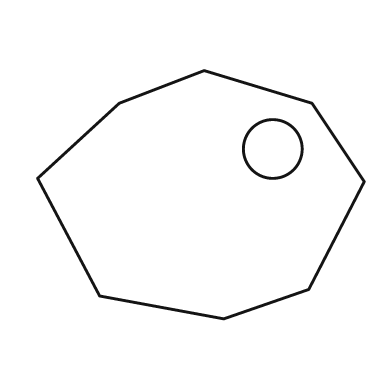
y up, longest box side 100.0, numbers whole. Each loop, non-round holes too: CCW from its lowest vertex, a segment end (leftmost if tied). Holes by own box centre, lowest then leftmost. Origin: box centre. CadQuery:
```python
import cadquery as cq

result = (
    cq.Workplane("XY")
    .moveTo(7.0, -38.0)
    .lineTo(33.0, -29.0)
    .lineTo(50.0, 4.0)
    .lineTo(34.0, 28.0)
    .lineTo(1.0, 38.0)
    .lineTo(-25.0, 28.0)
    .lineTo(-50.0, 5.0)
    .lineTo(-31.0, -31.0)
    .close()
    .moveTo(22.0, 14.0)
    .circle(9.0)
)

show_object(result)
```